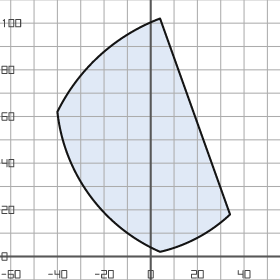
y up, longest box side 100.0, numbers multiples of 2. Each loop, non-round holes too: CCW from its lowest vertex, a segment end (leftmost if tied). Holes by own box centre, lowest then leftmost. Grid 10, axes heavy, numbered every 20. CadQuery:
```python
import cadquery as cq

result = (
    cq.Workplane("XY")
    .moveTo(4.0, 2.0)
    .threePointArc((20.0, 8.0), (34.0, 18.0))
    .lineTo(4.0, 102.0)
    .threePointArc((-22.0, 86.0), (-40.0, 62.0))
    .threePointArc((-26.0, 26.0), (4.0, 2.0))
    .close()
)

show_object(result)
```